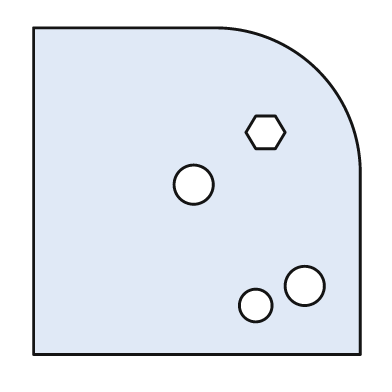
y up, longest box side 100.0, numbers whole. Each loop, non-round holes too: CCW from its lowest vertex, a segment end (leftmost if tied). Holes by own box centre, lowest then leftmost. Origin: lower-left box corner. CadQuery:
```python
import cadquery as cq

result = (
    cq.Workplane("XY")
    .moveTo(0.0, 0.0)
    .lineTo(100.0, 0.0)
    .lineTo(100.0, 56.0)
    .threePointArc((87.0, 87.0), (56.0, 100.0))
    .lineTo(0.0, 100.0)
    .close()
    .moveTo(68.0, 15.0)
    .circle(5.0)
    .moveTo(83.0, 21.0)
    .circle(6.0)
    .moveTo(49.0, 52.0)
    .circle(6.0)
    .moveTo(68.0, 63.0)
    .lineTo(74.0, 63.0)
    .lineTo(77.0, 68.0)
    .lineTo(74.0, 73.0)
    .lineTo(68.0, 73.0)
    .lineTo(65.0, 68.0)
    .close()
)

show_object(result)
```